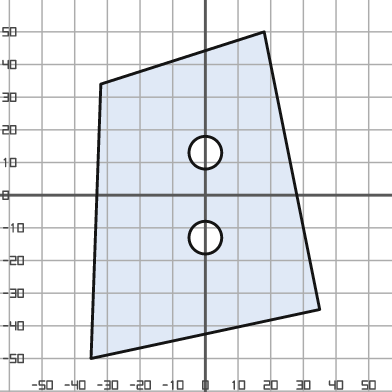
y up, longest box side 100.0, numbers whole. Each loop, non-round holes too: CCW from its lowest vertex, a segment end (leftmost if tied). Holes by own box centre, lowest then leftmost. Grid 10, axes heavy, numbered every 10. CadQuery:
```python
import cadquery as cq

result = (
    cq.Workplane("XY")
    .moveTo(-35.0, -50.0)
    .lineTo(35.0, -35.0)
    .lineTo(18.0, 50.0)
    .lineTo(-32.0, 34.0)
    .close()
    .moveTo(0.0, -13.0)
    .circle(5.0)
    .moveTo(0.0, 13.0)
    .circle(5.0)
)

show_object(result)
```